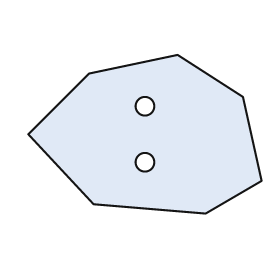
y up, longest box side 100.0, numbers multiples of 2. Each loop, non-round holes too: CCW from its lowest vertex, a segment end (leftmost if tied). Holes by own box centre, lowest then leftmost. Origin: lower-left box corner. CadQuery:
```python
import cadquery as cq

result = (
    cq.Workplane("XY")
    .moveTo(76.0, 0.0)
    .lineTo(100.0, 14.0)
    .lineTo(92.0, 50.0)
    .lineTo(64.0, 68.0)
    .lineTo(26.0, 60.0)
    .lineTo(0.0, 34.0)
    .lineTo(28.0, 4.0)
    .close()
    .moveTo(50.0, 22.0)
    .circle(4.0)
    .moveTo(50.0, 46.0)
    .circle(4.0)
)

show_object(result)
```